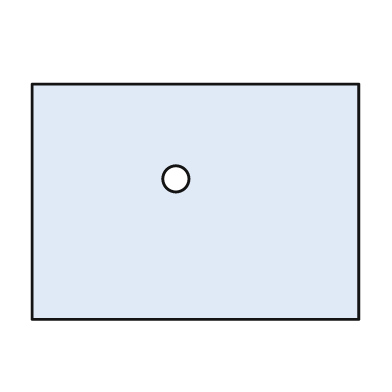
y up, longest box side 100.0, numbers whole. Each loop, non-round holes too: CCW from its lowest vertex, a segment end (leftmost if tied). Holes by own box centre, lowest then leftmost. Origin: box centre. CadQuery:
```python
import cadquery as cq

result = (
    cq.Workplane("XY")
    .moveTo(-50.0, -36.0)
    .lineTo(50.0, -36.0)
    .lineTo(50.0, 36.0)
    .lineTo(-50.0, 36.0)
    .close()
    .moveTo(-6.0, 7.0)
    .circle(4.0)
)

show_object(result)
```